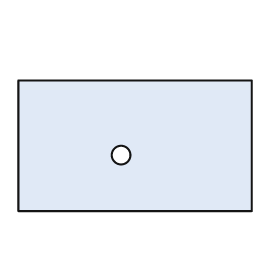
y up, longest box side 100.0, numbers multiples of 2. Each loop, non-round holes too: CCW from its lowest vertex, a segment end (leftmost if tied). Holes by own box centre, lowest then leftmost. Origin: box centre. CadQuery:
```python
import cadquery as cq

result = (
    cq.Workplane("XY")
    .moveTo(-50.0, -28.0)
    .lineTo(50.0, -28.0)
    .lineTo(50.0, 28.0)
    .lineTo(-50.0, 28.0)
    .close()
    .moveTo(-6.0, -4.0)
    .circle(4.0)
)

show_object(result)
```